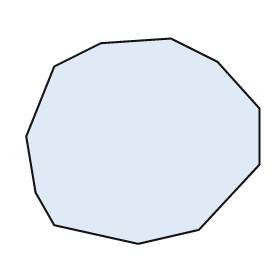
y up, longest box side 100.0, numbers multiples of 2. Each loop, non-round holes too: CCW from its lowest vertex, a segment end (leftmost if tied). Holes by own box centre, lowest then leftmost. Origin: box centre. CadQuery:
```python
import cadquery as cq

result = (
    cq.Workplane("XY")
    .moveTo(-2.0, -44.0)
    .lineTo(24.0, -38.0)
    .lineTo(50.0, -10.0)
    .lineTo(50.0, 14.0)
    .lineTo(32.0, 34.0)
    .lineTo(12.0, 44.0)
    .lineTo(-18.0, 42.0)
    .lineTo(-38.0, 32.0)
    .lineTo(-50.0, 2.0)
    .lineTo(-46.0, -22.0)
    .lineTo(-38.0, -36.0)
    .close()
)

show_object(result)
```